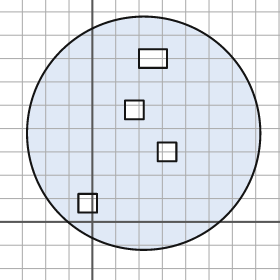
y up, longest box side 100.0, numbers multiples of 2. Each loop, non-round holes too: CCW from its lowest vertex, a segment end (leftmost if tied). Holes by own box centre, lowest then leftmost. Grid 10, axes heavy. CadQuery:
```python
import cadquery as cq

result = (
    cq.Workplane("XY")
    .moveTo(22.0, 38.0)
    .circle(50.0)
    .moveTo(-6.0, 4.0)
    .lineTo(2.0, 4.0)
    .lineTo(2.0, 12.0)
    .lineTo(-6.0, 12.0)
    .close()
    .moveTo(28.0, 26.0)
    .lineTo(36.0, 26.0)
    .lineTo(36.0, 34.0)
    .lineTo(28.0, 34.0)
    .close()
    .moveTo(14.0, 44.0)
    .lineTo(22.0, 44.0)
    .lineTo(22.0, 52.0)
    .lineTo(14.0, 52.0)
    .close()
    .moveTo(20.0, 66.0)
    .lineTo(32.0, 66.0)
    .lineTo(32.0, 74.0)
    .lineTo(20.0, 74.0)
    .close()
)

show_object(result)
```